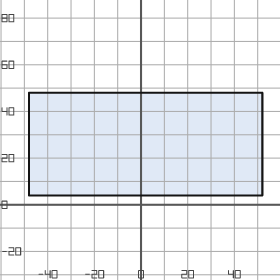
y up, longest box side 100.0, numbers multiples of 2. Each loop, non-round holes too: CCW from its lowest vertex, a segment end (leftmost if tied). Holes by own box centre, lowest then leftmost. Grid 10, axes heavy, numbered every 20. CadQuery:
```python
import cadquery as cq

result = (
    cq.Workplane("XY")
    .moveTo(-48.0, 4.0)
    .lineTo(52.0, 4.0)
    .lineTo(52.0, 48.0)
    .lineTo(-48.0, 48.0)
    .close()
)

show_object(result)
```